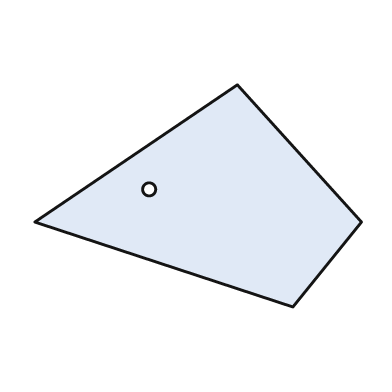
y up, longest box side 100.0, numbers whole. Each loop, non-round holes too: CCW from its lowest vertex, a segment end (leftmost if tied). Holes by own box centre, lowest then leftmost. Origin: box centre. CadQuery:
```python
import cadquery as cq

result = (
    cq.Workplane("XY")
    .moveTo(29.0, -34.0)
    .lineTo(50.0, -8.0)
    .lineTo(12.0, 34.0)
    .lineTo(-50.0, -8.0)
    .close()
    .moveTo(-15.0, 2.0)
    .circle(2.0)
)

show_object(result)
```